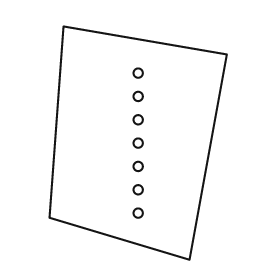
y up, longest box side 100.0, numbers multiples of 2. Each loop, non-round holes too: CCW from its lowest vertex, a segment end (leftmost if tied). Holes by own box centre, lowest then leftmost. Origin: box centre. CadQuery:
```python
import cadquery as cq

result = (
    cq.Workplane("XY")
    .moveTo(22.0, -50.0)
    .lineTo(38.0, 38.0)
    .lineTo(-32.0, 50.0)
    .lineTo(-38.0, -32.0)
    .close()
    .moveTo(0.0, -30.0)
    .circle(2.0)
    .moveTo(0.0, -20.0)
    .circle(2.0)
    .moveTo(0.0, -10.0)
    .circle(2.0)
    .moveTo(0.0, 0.0)
    .circle(2.0)
    .moveTo(0.0, 10.0)
    .circle(2.0)
    .moveTo(0.0, 20.0)
    .circle(2.0)
    .moveTo(0.0, 30.0)
    .circle(2.0)
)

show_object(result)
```